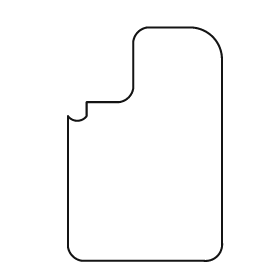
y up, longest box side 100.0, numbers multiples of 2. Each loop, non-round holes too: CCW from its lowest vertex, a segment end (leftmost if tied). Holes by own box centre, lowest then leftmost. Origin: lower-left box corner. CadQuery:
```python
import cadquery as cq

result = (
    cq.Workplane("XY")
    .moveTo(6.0, 0.0)
    .lineTo(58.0, 0.0)
    .threePointArc((64.0, 2.0), (66.0, 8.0))
    .lineTo(66.0, 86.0)
    .threePointArc((62.0, 96.0), (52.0, 100.0))
    .lineTo(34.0, 100.0)
    .threePointArc((30.0, 98.0), (28.0, 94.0))
    .lineTo(28.0, 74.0)
    .threePointArc((26.0, 70.0), (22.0, 68.0))
    .lineTo(8.0, 68.0)
    .lineTo(8.0, 62.0)
    .threePointArc((4.0, 60.0), (0.0, 62.0))
    .lineTo(0.0, 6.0)
    .threePointArc((2.0, 2.0), (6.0, 0.0))
    .close()
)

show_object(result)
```